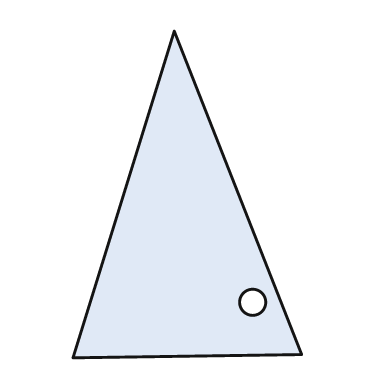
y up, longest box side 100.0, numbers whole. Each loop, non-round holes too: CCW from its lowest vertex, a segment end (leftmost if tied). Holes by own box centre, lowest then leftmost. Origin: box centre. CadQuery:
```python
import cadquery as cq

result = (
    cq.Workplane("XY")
    .moveTo(-35.0, -50.0)
    .lineTo(35.0, -49.0)
    .lineTo(-4.0, 50.0)
    .close()
    .moveTo(20.0, -33.0)
    .circle(4.0)
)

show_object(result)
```